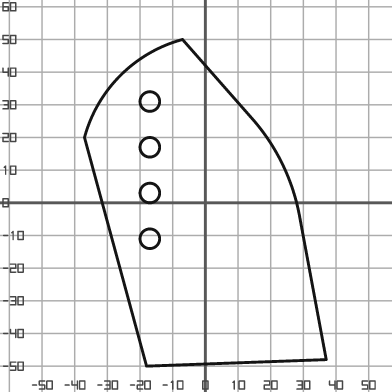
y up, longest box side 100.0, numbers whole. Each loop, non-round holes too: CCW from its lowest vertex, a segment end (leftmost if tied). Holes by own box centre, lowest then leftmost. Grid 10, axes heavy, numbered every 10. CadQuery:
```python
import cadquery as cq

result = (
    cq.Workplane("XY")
    .moveTo(-18.0, -50.0)
    .lineTo(37.0, -48.0)
    .lineTo(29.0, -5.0)
    .threePointArc((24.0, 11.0), (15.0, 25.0))
    .lineTo(-7.0, 50.0)
    .threePointArc((-26.0, 39.0), (-37.0, 20.0))
    .close()
    .moveTo(-17.0, -11.0)
    .circle(3.0)
    .moveTo(-17.0, 3.0)
    .circle(3.0)
    .moveTo(-17.0, 17.0)
    .circle(3.0)
    .moveTo(-17.0, 31.0)
    .circle(3.0)
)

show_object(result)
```